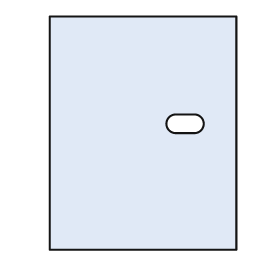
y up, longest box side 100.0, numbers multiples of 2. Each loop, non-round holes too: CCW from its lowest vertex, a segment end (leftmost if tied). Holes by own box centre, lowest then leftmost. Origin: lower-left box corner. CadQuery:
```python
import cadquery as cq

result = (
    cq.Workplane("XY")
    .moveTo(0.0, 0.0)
    .lineTo(80.0, 0.0)
    .lineTo(80.0, 100.0)
    .lineTo(0.0, 100.0)
    .close()
    .moveTo(54.0, 50.0)
    .lineTo(62.0, 50.0)
    .threePointArc((66.0, 54.0), (62.0, 58.0))
    .lineTo(54.0, 58.0)
    .threePointArc((50.0, 54.0), (54.0, 50.0))
    .close()
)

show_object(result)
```